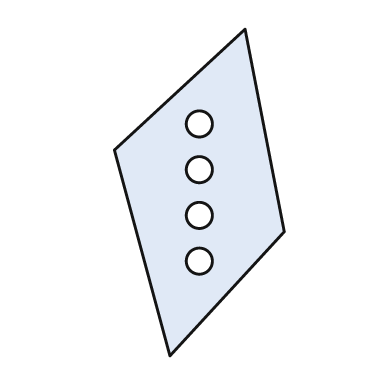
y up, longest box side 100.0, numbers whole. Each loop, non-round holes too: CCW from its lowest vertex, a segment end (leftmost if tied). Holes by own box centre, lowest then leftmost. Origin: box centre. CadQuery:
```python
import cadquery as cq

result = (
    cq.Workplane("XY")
    .moveTo(-9.0, -50.0)
    .lineTo(26.0, -12.0)
    .lineTo(14.0, 50.0)
    .lineTo(-26.0, 13.0)
    .close()
    .moveTo(0.0, -21.0)
    .circle(4.0)
    .moveTo(0.0, -7.0)
    .circle(4.0)
    .moveTo(0.0, 7.0)
    .circle(4.0)
    .moveTo(0.0, 21.0)
    .circle(4.0)
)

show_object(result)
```